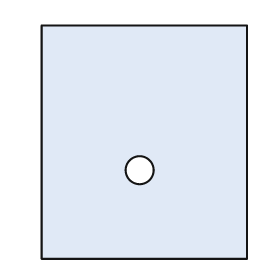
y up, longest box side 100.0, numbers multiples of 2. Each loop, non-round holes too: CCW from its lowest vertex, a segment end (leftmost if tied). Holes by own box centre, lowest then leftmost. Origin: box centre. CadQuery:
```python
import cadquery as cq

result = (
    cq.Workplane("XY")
    .moveTo(-44.0, -50.0)
    .lineTo(44.0, -50.0)
    .lineTo(44.0, 50.0)
    .lineTo(-44.0, 50.0)
    .close()
    .moveTo(-2.0, -12.0)
    .circle(6.0)
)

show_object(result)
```